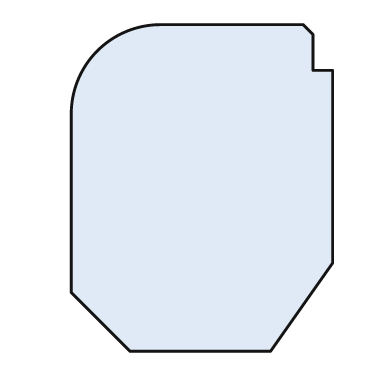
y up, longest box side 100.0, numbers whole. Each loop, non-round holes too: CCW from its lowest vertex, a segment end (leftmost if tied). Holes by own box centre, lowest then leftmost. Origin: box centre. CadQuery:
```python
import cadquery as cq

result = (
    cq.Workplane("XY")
    .moveTo(-22.0, -50.0)
    .lineTo(21.0, -50.0)
    .lineTo(40.0, -23.0)
    .lineTo(40.0, 36.0)
    .lineTo(34.0, 36.0)
    .lineTo(34.0, 47.0)
    .lineTo(31.0, 50.0)
    .lineTo(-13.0, 50.0)
    .threePointArc((-32.0, 42.0), (-40.0, 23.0))
    .lineTo(-40.0, -32.0)
    .close()
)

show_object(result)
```